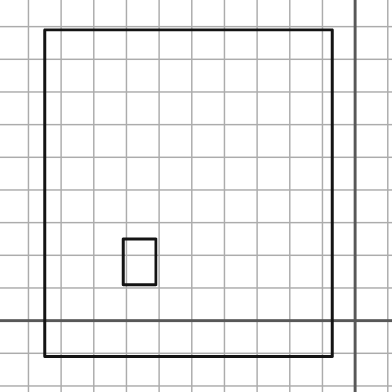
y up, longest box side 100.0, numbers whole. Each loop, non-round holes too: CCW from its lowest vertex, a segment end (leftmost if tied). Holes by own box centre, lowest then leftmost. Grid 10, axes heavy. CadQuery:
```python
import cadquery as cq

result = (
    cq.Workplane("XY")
    .moveTo(-95.0, -11.0)
    .lineTo(-7.0, -11.0)
    .lineTo(-7.0, 89.0)
    .lineTo(-95.0, 89.0)
    .close()
    .moveTo(-71.0, 11.0)
    .lineTo(-61.0, 11.0)
    .lineTo(-61.0, 25.0)
    .lineTo(-71.0, 25.0)
    .close()
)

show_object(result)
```